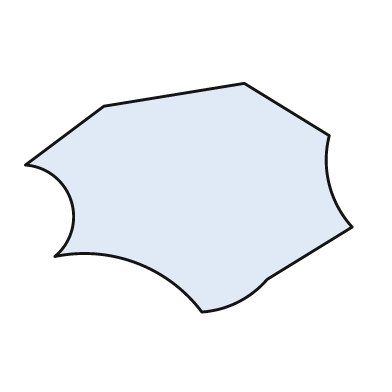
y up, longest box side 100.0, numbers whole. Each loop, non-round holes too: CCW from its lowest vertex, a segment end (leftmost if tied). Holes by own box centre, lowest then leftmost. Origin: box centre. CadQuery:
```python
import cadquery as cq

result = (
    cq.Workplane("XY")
    .moveTo(4.0, -35.0)
    .threePointArc((15.0, -32.0), (24.0, -25.0))
    .lineTo(50.0, -9.0)
    .threePointArc((43.0, 4.0), (43.0, 19.0))
    .lineTo(17.0, 35.0)
    .lineTo(-26.0, 28.0)
    .lineTo(-50.0, 10.0)
    .threePointArc((-36.0, -1.0), (-41.0, -18.0))
    .threePointArc((-16.0, -20.0), (4.0, -35.0))
    .close()
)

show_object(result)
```